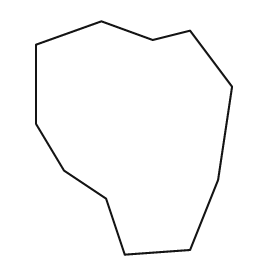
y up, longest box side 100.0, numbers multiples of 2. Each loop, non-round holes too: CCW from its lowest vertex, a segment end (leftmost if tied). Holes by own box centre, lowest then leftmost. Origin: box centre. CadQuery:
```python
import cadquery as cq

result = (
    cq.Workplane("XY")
    .moveTo(-4.0, -50.0)
    .lineTo(24.0, -48.0)
    .lineTo(36.0, -18.0)
    .lineTo(42.0, 22.0)
    .lineTo(24.0, 46.0)
    .lineTo(8.0, 42.0)
    .lineTo(-14.0, 50.0)
    .lineTo(-42.0, 40.0)
    .lineTo(-42.0, 6.0)
    .lineTo(-30.0, -14.0)
    .lineTo(-12.0, -26.0)
    .close()
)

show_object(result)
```